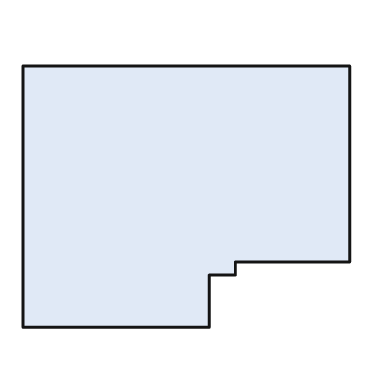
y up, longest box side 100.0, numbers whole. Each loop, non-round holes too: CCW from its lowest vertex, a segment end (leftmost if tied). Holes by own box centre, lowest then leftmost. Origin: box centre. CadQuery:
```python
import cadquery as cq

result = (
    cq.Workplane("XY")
    .moveTo(-50.0, -40.0)
    .lineTo(7.0, -40.0)
    .lineTo(7.0, -24.0)
    .lineTo(15.0, -24.0)
    .lineTo(15.0, -20.0)
    .lineTo(50.0, -20.0)
    .lineTo(50.0, 40.0)
    .lineTo(-50.0, 40.0)
    .close()
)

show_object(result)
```